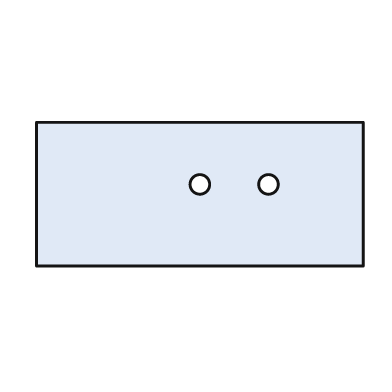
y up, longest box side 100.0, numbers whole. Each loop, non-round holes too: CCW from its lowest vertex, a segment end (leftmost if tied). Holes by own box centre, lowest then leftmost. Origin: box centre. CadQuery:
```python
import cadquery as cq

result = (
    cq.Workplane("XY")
    .moveTo(-50.0, -22.0)
    .lineTo(50.0, -22.0)
    .lineTo(50.0, 22.0)
    .lineTo(-50.0, 22.0)
    .close()
    .moveTo(0.0, 3.0)
    .circle(3.0)
    .moveTo(21.0, 3.0)
    .circle(3.0)
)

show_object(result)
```